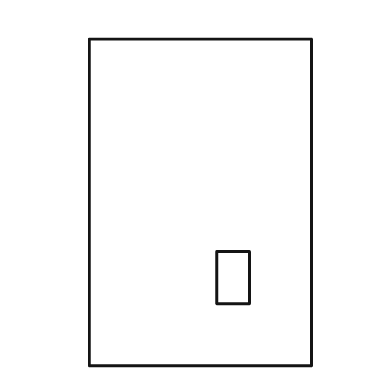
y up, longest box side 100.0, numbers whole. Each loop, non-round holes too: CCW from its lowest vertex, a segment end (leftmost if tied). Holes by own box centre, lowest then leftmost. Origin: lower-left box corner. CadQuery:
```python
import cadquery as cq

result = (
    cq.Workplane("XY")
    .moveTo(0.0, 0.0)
    .lineTo(68.0, 0.0)
    .lineTo(68.0, 100.0)
    .lineTo(0.0, 100.0)
    .close()
    .moveTo(39.0, 19.0)
    .lineTo(49.0, 19.0)
    .lineTo(49.0, 35.0)
    .lineTo(39.0, 35.0)
    .close()
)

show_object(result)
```